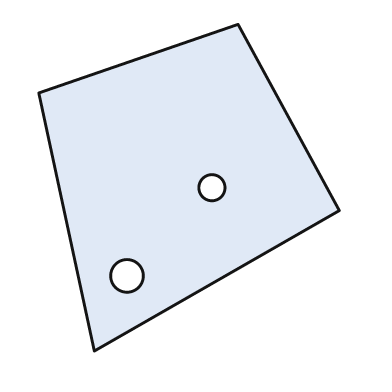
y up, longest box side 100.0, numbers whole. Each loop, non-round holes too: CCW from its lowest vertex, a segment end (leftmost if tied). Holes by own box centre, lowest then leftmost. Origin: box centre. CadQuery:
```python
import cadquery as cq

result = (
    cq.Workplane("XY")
    .moveTo(-29.0, -50.0)
    .lineTo(46.0, -7.0)
    .lineTo(15.0, 50.0)
    .lineTo(-46.0, 29.0)
    .close()
    .moveTo(-19.0, -27.0)
    .circle(5.0)
    .moveTo(7.0, 0.0)
    .circle(4.0)
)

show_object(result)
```